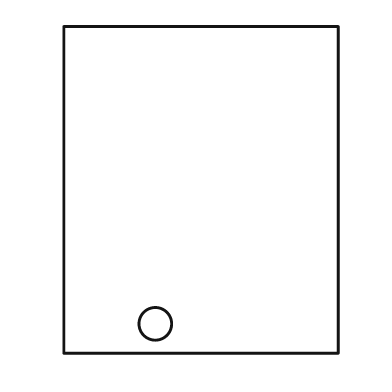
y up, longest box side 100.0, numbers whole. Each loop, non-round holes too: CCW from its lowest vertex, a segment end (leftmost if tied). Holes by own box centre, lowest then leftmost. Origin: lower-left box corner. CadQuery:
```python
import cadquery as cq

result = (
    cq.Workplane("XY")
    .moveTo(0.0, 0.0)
    .lineTo(84.0, 0.0)
    .lineTo(84.0, 100.0)
    .lineTo(0.0, 100.0)
    .close()
    .moveTo(28.0, 9.0)
    .circle(5.0)
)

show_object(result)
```